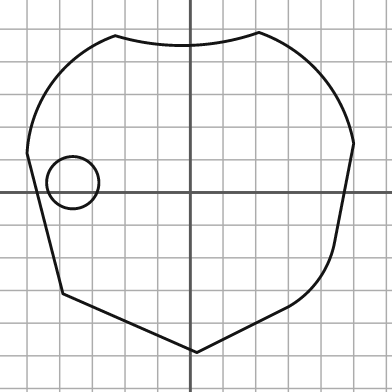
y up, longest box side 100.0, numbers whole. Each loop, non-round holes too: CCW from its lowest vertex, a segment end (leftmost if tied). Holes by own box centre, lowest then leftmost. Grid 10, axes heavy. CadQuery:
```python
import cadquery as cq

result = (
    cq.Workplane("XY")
    .moveTo(2.0, -49.0)
    .lineTo(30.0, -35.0)
    .threePointArc((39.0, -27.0), (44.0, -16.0))
    .lineTo(50.0, 15.0)
    .threePointArc((40.0, 36.0), (21.0, 49.0))
    .threePointArc((-1.0, 45.0), (-23.0, 48.0))
    .threePointArc((-42.0, 34.0), (-50.0, 12.0))
    .lineTo(-39.0, -31.0)
    .close()
    .moveTo(-36.0, 3.0)
    .circle(8.0)
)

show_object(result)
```